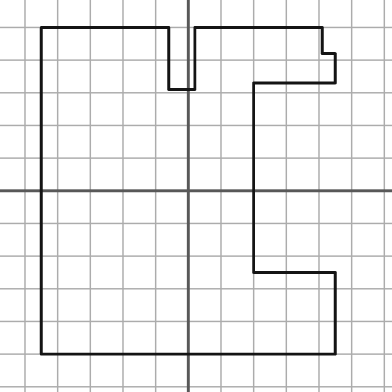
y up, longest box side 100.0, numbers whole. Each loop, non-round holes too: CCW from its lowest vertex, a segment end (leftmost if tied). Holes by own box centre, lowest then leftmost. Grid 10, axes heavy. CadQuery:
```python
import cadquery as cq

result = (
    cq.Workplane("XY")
    .moveTo(-45.0, -50.0)
    .lineTo(45.0, -50.0)
    .lineTo(45.0, -25.0)
    .lineTo(20.0, -25.0)
    .lineTo(20.0, 33.0)
    .lineTo(45.0, 33.0)
    .lineTo(45.0, 42.0)
    .lineTo(41.0, 42.0)
    .lineTo(41.0, 50.0)
    .lineTo(2.0, 50.0)
    .lineTo(2.0, 31.0)
    .lineTo(-6.0, 31.0)
    .lineTo(-6.0, 50.0)
    .lineTo(-45.0, 50.0)
    .close()
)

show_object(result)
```